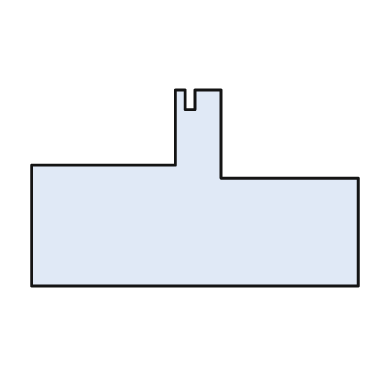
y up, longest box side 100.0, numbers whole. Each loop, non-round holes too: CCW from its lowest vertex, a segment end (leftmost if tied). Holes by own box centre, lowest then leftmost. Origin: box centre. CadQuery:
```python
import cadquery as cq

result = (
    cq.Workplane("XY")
    .moveTo(-50.0, -30.0)
    .lineTo(50.0, -30.0)
    .lineTo(50.0, 3.0)
    .lineTo(8.0, 3.0)
    .lineTo(8.0, 30.0)
    .lineTo(0.0, 30.0)
    .lineTo(0.0, 24.0)
    .lineTo(-3.0, 24.0)
    .lineTo(-3.0, 30.0)
    .lineTo(-6.0, 30.0)
    .lineTo(-6.0, 7.0)
    .lineTo(-50.0, 7.0)
    .close()
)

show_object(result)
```